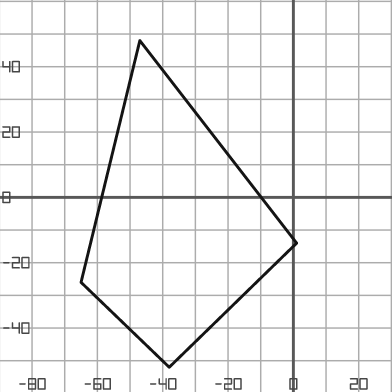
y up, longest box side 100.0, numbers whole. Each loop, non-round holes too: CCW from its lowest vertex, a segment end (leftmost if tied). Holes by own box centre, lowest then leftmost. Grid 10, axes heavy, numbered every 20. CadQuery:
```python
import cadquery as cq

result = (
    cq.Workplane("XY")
    .moveTo(-38.0, -52.0)
    .lineTo(1.0, -14.0)
    .lineTo(-47.0, 48.0)
    .lineTo(-65.0, -26.0)
    .close()
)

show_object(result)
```